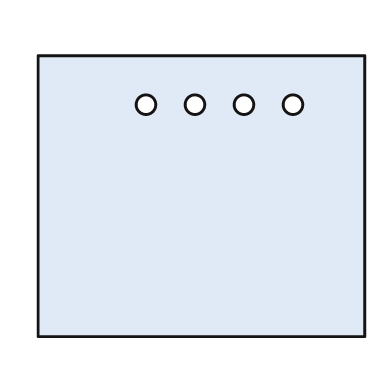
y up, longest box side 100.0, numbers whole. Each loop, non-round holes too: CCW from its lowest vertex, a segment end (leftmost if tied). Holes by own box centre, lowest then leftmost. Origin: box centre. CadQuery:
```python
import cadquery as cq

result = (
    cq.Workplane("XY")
    .moveTo(-50.0, -43.0)
    .lineTo(50.0, -43.0)
    .lineTo(50.0, 43.0)
    .lineTo(-50.0, 43.0)
    .close()
    .moveTo(-17.0, 28.0)
    .circle(3.0)
    .moveTo(-2.0, 28.0)
    .circle(3.0)
    .moveTo(13.0, 28.0)
    .circle(3.0)
    .moveTo(28.0, 28.0)
    .circle(3.0)
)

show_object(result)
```